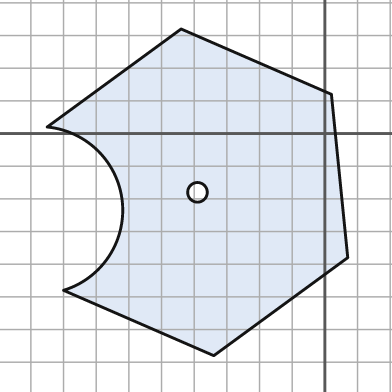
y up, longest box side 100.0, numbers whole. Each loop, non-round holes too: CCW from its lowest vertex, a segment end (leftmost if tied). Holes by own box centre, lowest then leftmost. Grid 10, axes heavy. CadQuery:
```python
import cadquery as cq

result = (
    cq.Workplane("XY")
    .moveTo(-34.0, -68.0)
    .lineTo(7.0, -38.0)
    .lineTo(2.0, 12.0)
    .lineTo(-44.0, 32.0)
    .lineTo(-85.0, 2.0)
    .threePointArc((-62.0, -21.0), (-80.0, -48.0))
    .close()
    .moveTo(-39.0, -18.0)
    .circle(3.0)
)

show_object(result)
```